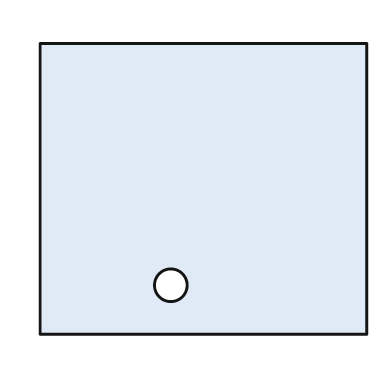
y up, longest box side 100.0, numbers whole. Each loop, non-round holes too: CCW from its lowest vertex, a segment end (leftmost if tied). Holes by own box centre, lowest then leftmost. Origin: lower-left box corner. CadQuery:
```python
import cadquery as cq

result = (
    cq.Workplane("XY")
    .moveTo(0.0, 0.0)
    .lineTo(100.0, 0.0)
    .lineTo(100.0, 89.0)
    .lineTo(0.0, 89.0)
    .close()
    .moveTo(40.0, 15.0)
    .circle(5.0)
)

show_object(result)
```